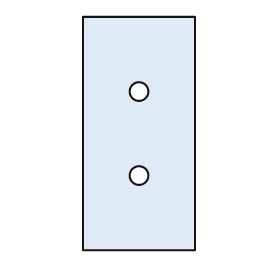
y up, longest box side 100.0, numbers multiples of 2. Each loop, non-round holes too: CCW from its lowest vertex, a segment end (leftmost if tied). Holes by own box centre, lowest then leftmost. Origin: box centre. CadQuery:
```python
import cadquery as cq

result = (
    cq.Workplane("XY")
    .moveTo(-24.0, -50.0)
    .lineTo(24.0, -50.0)
    .lineTo(24.0, 50.0)
    .lineTo(-24.0, 50.0)
    .close()
    .moveTo(0.0, -18.0)
    .circle(4.0)
    .moveTo(0.0, 18.0)
    .circle(4.0)
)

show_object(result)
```